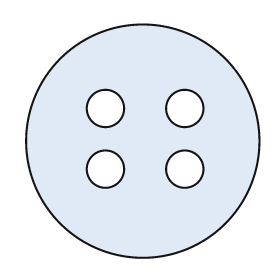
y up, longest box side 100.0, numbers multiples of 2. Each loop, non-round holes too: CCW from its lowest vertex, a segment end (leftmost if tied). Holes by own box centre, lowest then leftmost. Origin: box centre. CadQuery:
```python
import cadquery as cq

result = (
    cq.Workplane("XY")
    .moveTo(0.0, 0.0)
    .circle(50.0)
    .moveTo(-16.0, -12.0)
    .circle(8.0)
    .moveTo(18.0, -12.0)
    .circle(8.0)
    .moveTo(-16.0, 14.0)
    .circle(8.0)
    .moveTo(18.0, 14.0)
    .circle(8.0)
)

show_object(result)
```